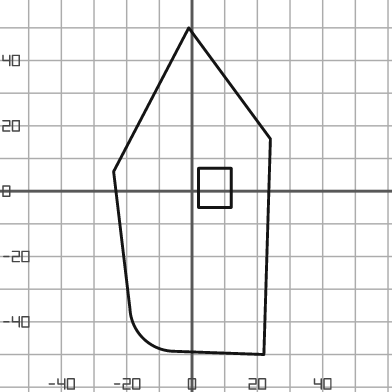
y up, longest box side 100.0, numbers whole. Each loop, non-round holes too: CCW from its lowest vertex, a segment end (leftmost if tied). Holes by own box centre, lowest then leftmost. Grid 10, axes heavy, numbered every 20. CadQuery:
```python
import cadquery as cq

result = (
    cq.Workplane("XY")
    .moveTo(22.0, -50.0)
    .lineTo(24.0, 16.0)
    .lineTo(-1.0, 50.0)
    .lineTo(-24.0, 6.0)
    .lineTo(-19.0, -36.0)
    .threePointArc((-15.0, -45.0), (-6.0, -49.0))
    .close()
    .moveTo(2.0, -5.0)
    .lineTo(12.0, -5.0)
    .lineTo(12.0, 7.0)
    .lineTo(2.0, 7.0)
    .close()
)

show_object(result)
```